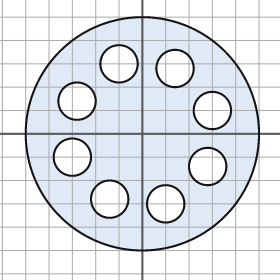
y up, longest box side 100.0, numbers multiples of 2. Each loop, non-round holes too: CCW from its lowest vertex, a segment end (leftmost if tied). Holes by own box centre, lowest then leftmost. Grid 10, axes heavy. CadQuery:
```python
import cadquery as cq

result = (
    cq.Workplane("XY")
    .moveTo(0.0, 0.0)
    .circle(50.0)
    .moveTo(10.0, -30.0)
    .circle(8.0)
    .moveTo(-14.0, -28.0)
    .circle(8.0)
    .moveTo(28.0, -14.0)
    .circle(8.0)
    .moveTo(-30.0, -10.0)
    .circle(8.0)
    .moveTo(30.0, 10.0)
    .circle(8.0)
    .moveTo(-28.0, 14.0)
    .circle(8.0)
    .moveTo(14.0, 28.0)
    .circle(8.0)
    .moveTo(-10.0, 30.0)
    .circle(8.0)
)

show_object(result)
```